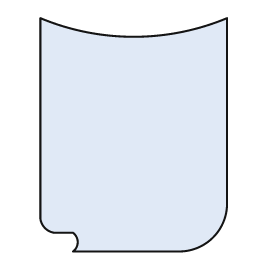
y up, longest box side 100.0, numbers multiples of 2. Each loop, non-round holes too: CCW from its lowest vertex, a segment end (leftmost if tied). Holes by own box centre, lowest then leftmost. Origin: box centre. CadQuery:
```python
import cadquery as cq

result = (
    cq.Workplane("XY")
    .moveTo(-26.0, -50.0)
    .lineTo(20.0, -50.0)
    .threePointArc((34.0, -44.0), (40.0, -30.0))
    .lineTo(40.0, 50.0)
    .threePointArc((0.0, 42.0), (-40.0, 50.0))
    .lineTo(-40.0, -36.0)
    .threePointArc((-38.0, -40.0), (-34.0, -42.0))
    .lineTo(-26.0, -42.0)
    .threePointArc((-24.0, -46.0), (-26.0, -50.0))
    .close()
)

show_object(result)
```